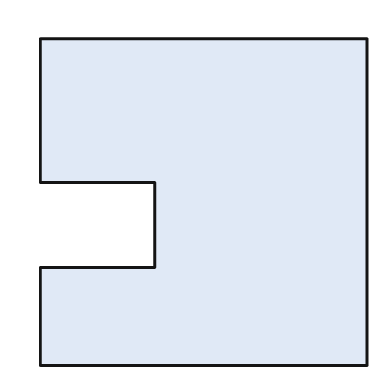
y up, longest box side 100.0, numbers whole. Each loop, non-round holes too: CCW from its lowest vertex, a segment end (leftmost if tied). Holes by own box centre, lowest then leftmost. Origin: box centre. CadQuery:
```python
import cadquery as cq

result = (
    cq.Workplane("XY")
    .moveTo(-50.0, -50.0)
    .lineTo(50.0, -50.0)
    .lineTo(50.0, 50.0)
    .lineTo(-50.0, 50.0)
    .lineTo(-50.0, 6.0)
    .lineTo(-15.0, 6.0)
    .lineTo(-15.0, -20.0)
    .lineTo(-50.0, -20.0)
    .close()
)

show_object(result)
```